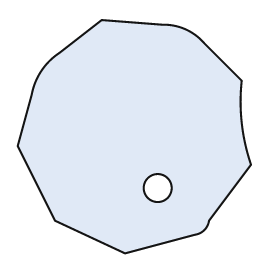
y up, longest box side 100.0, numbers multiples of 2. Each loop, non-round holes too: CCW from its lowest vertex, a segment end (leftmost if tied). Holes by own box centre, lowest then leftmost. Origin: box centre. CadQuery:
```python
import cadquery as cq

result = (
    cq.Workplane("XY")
    .moveTo(-4.0, -50.0)
    .lineTo(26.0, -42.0)
    .threePointArc((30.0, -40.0), (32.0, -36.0))
    .lineTo(50.0, -12.0)
    .threePointArc((46.0, 6.0), (46.0, 24.0))
    .lineTo(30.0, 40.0)
    .threePointArc((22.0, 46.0), (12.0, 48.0))
    .lineTo(-14.0, 50.0)
    .lineTo(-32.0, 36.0)
    .threePointArc((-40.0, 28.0), (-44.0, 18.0))
    .lineTo(-50.0, -4.0)
    .lineTo(-34.0, -36.0)
    .close()
    .moveTo(10.0, -22.0)
    .circle(6.0)
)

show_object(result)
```